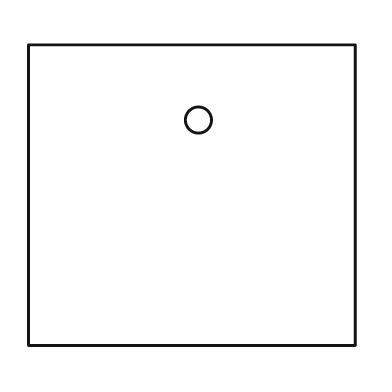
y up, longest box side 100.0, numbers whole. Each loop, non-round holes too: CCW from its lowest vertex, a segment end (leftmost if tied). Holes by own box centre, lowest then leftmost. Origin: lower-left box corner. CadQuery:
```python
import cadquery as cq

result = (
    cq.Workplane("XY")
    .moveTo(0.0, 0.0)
    .lineTo(100.0, 0.0)
    .lineTo(100.0, 92.0)
    .lineTo(0.0, 92.0)
    .close()
    .moveTo(52.0, 69.0)
    .circle(4.0)
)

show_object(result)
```